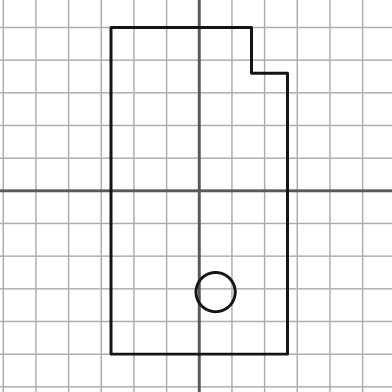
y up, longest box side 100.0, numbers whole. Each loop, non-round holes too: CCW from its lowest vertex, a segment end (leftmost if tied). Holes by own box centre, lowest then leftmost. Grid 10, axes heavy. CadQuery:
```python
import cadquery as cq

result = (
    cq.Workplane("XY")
    .moveTo(-27.0, -50.0)
    .lineTo(27.0, -50.0)
    .lineTo(27.0, 36.0)
    .lineTo(16.0, 36.0)
    .lineTo(16.0, 50.0)
    .lineTo(-27.0, 50.0)
    .close()
    .moveTo(5.0, -31.0)
    .circle(6.0)
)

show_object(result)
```